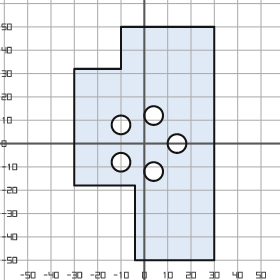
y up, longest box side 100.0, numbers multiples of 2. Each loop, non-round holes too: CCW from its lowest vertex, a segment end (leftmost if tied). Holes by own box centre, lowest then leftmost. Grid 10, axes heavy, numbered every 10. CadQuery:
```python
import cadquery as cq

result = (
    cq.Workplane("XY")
    .moveTo(-4.0, -50.0)
    .lineTo(30.0, -50.0)
    .lineTo(30.0, 50.0)
    .lineTo(-10.0, 50.0)
    .lineTo(-10.0, 32.0)
    .lineTo(-30.0, 32.0)
    .lineTo(-30.0, -18.0)
    .lineTo(-4.0, -18.0)
    .close()
    .moveTo(4.0, -12.0)
    .circle(4.0)
    .moveTo(-10.0, -8.0)
    .circle(4.0)
    .moveTo(14.0, 0.0)
    .circle(4.0)
    .moveTo(-10.0, 8.0)
    .circle(4.0)
    .moveTo(4.0, 12.0)
    .circle(4.0)
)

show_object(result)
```